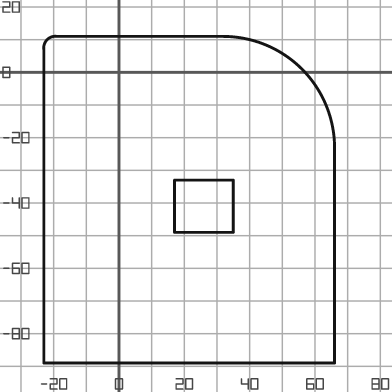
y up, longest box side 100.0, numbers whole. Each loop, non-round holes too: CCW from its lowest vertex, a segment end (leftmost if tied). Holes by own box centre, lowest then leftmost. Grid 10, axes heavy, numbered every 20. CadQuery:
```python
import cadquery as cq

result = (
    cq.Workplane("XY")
    .moveTo(-23.0, -89.0)
    .lineTo(66.0, -89.0)
    .lineTo(66.0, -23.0)
    .threePointArc((56.0, 1.0), (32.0, 11.0))
    .lineTo(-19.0, 11.0)
    .threePointArc((-22.0, 10.0), (-23.0, 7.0))
    .close()
    .moveTo(17.0, -49.0)
    .lineTo(35.0, -49.0)
    .lineTo(35.0, -33.0)
    .lineTo(17.0, -33.0)
    .close()
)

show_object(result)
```